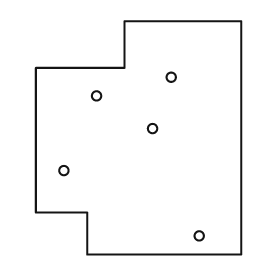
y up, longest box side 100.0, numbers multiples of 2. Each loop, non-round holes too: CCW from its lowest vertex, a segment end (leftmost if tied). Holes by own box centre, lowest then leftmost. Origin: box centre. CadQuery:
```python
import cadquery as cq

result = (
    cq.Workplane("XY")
    .moveTo(-22.0, -50.0)
    .lineTo(44.0, -50.0)
    .lineTo(44.0, 50.0)
    .lineTo(-6.0, 50.0)
    .lineTo(-6.0, 30.0)
    .lineTo(-44.0, 30.0)
    .lineTo(-44.0, -32.0)
    .lineTo(-22.0, -32.0)
    .close()
    .moveTo(26.0, -42.0)
    .circle(2.0)
    .moveTo(-32.0, -14.0)
    .circle(2.0)
    .moveTo(6.0, 4.0)
    .circle(2.0)
    .moveTo(-18.0, 18.0)
    .circle(2.0)
    .moveTo(14.0, 26.0)
    .circle(2.0)
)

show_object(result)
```